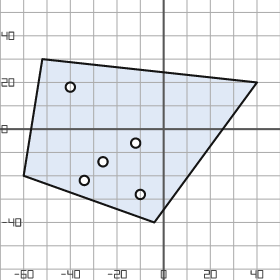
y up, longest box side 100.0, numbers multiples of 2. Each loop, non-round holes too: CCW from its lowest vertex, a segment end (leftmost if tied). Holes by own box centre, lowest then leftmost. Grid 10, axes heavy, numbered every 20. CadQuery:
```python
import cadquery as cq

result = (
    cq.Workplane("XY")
    .moveTo(-4.0, -40.0)
    .lineTo(40.0, 20.0)
    .lineTo(-52.0, 30.0)
    .lineTo(-60.0, -20.0)
    .close()
    .moveTo(-10.0, -28.0)
    .circle(2.0)
    .moveTo(-34.0, -22.0)
    .circle(2.0)
    .moveTo(-26.0, -14.0)
    .circle(2.0)
    .moveTo(-12.0, -6.0)
    .circle(2.0)
    .moveTo(-40.0, 18.0)
    .circle(2.0)
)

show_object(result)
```